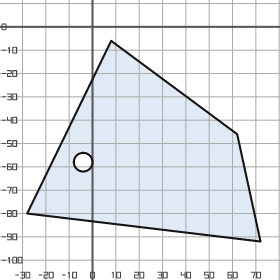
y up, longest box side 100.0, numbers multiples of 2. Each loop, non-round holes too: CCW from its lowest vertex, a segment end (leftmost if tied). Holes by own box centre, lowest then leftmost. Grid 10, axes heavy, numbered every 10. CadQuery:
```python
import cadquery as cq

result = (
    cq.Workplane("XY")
    .moveTo(72.0, -92.0)
    .lineTo(62.0, -46.0)
    .lineTo(8.0, -6.0)
    .lineTo(-28.0, -80.0)
    .close()
    .moveTo(-4.0, -58.0)
    .circle(4.0)
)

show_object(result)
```